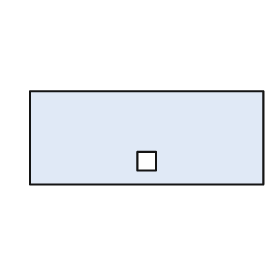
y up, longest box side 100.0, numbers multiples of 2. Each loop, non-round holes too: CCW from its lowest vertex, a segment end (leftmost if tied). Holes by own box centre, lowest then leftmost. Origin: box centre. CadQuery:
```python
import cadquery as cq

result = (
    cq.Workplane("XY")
    .moveTo(-50.0, -20.0)
    .lineTo(50.0, -20.0)
    .lineTo(50.0, 20.0)
    .lineTo(-50.0, 20.0)
    .close()
    .moveTo(-4.0, -14.0)
    .lineTo(4.0, -14.0)
    .lineTo(4.0, -6.0)
    .lineTo(-4.0, -6.0)
    .close()
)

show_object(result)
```